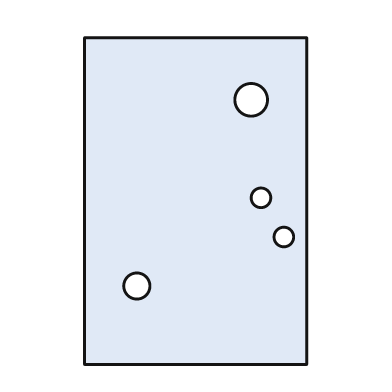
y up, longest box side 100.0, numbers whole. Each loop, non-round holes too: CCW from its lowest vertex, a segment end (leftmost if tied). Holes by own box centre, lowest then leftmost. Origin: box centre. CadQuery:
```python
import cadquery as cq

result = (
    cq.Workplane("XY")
    .moveTo(-34.0, -50.0)
    .lineTo(34.0, -50.0)
    .lineTo(34.0, 50.0)
    .lineTo(-34.0, 50.0)
    .close()
    .moveTo(-18.0, -26.0)
    .circle(4.0)
    .moveTo(27.0, -11.0)
    .circle(3.0)
    .moveTo(20.0, 1.0)
    .circle(3.0)
    .moveTo(17.0, 31.0)
    .circle(5.0)
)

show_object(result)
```